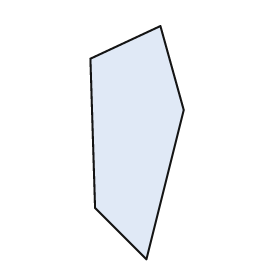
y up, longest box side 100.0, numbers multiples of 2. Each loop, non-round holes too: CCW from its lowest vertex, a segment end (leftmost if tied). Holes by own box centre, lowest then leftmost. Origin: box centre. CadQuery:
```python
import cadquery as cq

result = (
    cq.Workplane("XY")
    .moveTo(4.0, -50.0)
    .lineTo(20.0, 14.0)
    .lineTo(10.0, 50.0)
    .lineTo(-20.0, 36.0)
    .lineTo(-18.0, -28.0)
    .close()
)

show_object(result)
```